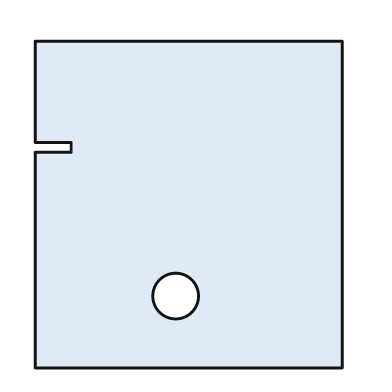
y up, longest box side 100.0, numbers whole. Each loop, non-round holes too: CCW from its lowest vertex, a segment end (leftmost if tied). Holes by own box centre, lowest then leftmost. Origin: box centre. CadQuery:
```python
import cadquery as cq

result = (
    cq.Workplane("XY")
    .moveTo(-47.0, -50.0)
    .lineTo(47.0, -50.0)
    .lineTo(47.0, 50.0)
    .lineTo(-47.0, 50.0)
    .lineTo(-47.0, 19.0)
    .lineTo(-36.0, 19.0)
    .lineTo(-36.0, 16.0)
    .lineTo(-47.0, 16.0)
    .close()
    .moveTo(-4.0, -28.0)
    .circle(7.0)
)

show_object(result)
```